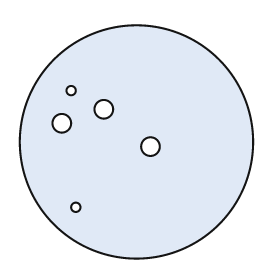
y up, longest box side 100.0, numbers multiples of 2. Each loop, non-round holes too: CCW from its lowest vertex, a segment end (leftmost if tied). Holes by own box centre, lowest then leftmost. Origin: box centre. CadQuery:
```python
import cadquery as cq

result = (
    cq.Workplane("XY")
    .moveTo(0.0, 0.0)
    .circle(50.0)
    .moveTo(-26.0, -28.0)
    .circle(2.0)
    .moveTo(6.0, -2.0)
    .circle(4.0)
    .moveTo(-32.0, 8.0)
    .circle(4.0)
    .moveTo(-14.0, 14.0)
    .circle(4.0)
    .moveTo(-28.0, 22.0)
    .circle(2.0)
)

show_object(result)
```